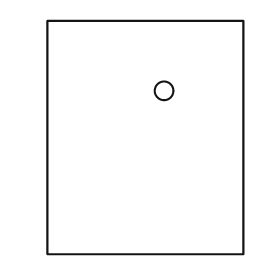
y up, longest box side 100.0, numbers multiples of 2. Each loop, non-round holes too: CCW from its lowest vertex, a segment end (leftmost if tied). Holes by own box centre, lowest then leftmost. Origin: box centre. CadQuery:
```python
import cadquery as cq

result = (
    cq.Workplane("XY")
    .moveTo(-42.0, -50.0)
    .lineTo(42.0, -50.0)
    .lineTo(42.0, 50.0)
    .lineTo(-42.0, 50.0)
    .close()
    .moveTo(8.0, 20.0)
    .circle(4.0)
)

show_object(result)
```